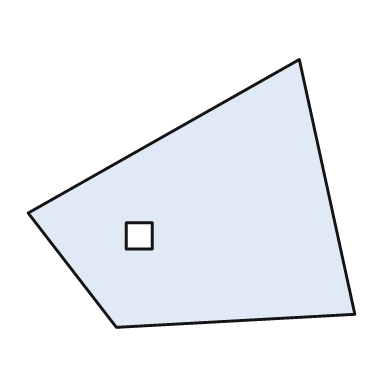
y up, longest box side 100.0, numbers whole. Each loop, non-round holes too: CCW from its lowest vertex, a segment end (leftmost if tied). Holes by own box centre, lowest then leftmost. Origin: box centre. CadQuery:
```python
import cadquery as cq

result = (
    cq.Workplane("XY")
    .moveTo(-23.0, -41.0)
    .lineTo(50.0, -37.0)
    .lineTo(33.0, 41.0)
    .lineTo(-50.0, -6.0)
    .close()
    .moveTo(-20.0, -17.0)
    .lineTo(-12.0, -17.0)
    .lineTo(-12.0, -9.0)
    .lineTo(-20.0, -9.0)
    .close()
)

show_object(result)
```